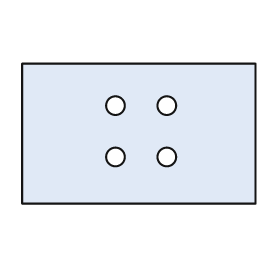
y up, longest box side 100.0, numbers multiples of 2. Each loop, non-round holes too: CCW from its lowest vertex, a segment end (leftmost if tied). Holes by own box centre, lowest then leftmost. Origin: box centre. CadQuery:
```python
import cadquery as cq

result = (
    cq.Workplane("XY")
    .moveTo(-50.0, -30.0)
    .lineTo(50.0, -30.0)
    .lineTo(50.0, 30.0)
    .lineTo(-50.0, 30.0)
    .close()
    .moveTo(-10.0, -10.0)
    .circle(4.0)
    .moveTo(12.0, -10.0)
    .circle(4.0)
    .moveTo(-10.0, 12.0)
    .circle(4.0)
    .moveTo(12.0, 12.0)
    .circle(4.0)
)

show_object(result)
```